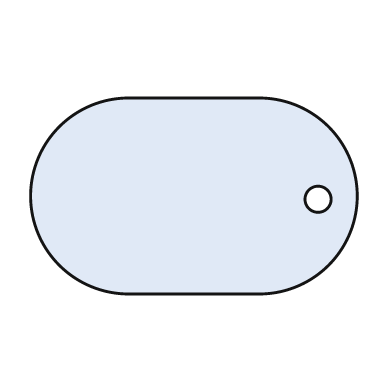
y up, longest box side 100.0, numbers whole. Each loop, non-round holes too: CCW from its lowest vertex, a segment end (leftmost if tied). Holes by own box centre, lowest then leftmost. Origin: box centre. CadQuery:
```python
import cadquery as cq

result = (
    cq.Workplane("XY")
    .moveTo(-20.0, -30.0)
    .lineTo(20.0, -30.0)
    .threePointArc((50.0, 0.0), (20.0, 30.0))
    .lineTo(-20.0, 30.0)
    .threePointArc((-50.0, 0.0), (-20.0, -30.0))
    .close()
    .moveTo(38.0, -1.0)
    .circle(4.0)
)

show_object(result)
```